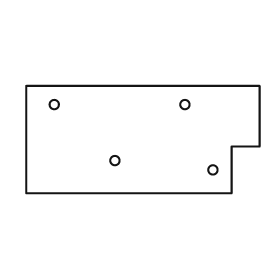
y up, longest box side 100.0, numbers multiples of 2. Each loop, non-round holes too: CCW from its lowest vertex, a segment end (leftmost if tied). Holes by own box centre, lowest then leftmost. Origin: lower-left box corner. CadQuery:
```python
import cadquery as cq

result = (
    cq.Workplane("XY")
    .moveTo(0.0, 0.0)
    .lineTo(88.0, 0.0)
    .lineTo(88.0, 20.0)
    .lineTo(100.0, 20.0)
    .lineTo(100.0, 46.0)
    .lineTo(0.0, 46.0)
    .close()
    .moveTo(80.0, 10.0)
    .circle(2.0)
    .moveTo(38.0, 14.0)
    .circle(2.0)
    .moveTo(12.0, 38.0)
    .circle(2.0)
    .moveTo(68.0, 38.0)
    .circle(2.0)
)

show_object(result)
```